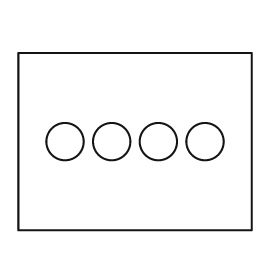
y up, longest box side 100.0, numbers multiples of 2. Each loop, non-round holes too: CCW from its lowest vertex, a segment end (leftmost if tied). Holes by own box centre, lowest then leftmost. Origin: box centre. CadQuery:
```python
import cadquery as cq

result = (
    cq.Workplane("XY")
    .moveTo(-50.0, -38.0)
    .lineTo(50.0, -38.0)
    .lineTo(50.0, 38.0)
    .lineTo(-50.0, 38.0)
    .close()
    .moveTo(-30.0, 0.0)
    .circle(8.0)
    .moveTo(-10.0, 0.0)
    .circle(8.0)
    .moveTo(10.0, 0.0)
    .circle(8.0)
    .moveTo(30.0, 0.0)
    .circle(8.0)
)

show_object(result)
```